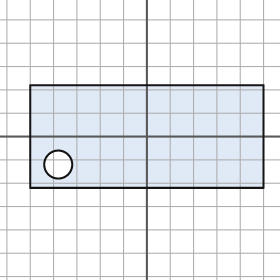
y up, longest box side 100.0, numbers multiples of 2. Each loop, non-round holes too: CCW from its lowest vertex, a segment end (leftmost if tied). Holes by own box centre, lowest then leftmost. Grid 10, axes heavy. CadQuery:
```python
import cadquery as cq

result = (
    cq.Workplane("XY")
    .moveTo(-50.0, -22.0)
    .lineTo(50.0, -22.0)
    .lineTo(50.0, 22.0)
    .lineTo(-50.0, 22.0)
    .close()
    .moveTo(-38.0, -12.0)
    .circle(6.0)
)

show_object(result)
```